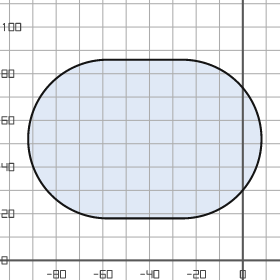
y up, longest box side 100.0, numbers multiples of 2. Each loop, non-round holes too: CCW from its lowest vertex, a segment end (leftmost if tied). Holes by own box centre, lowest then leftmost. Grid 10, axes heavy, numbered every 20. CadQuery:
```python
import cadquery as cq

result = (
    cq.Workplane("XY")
    .moveTo(-58.0, 18.0)
    .lineTo(-26.0, 18.0)
    .threePointArc((8.0, 52.0), (-26.0, 86.0))
    .lineTo(-58.0, 86.0)
    .threePointArc((-92.0, 52.0), (-58.0, 18.0))
    .close()
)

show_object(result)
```